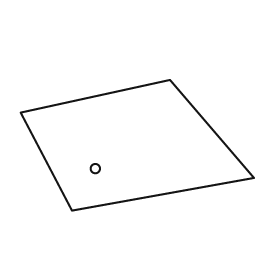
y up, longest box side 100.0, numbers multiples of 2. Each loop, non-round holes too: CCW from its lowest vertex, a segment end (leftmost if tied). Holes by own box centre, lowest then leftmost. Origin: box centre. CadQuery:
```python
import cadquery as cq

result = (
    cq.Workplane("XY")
    .moveTo(-28.0, -28.0)
    .lineTo(50.0, -14.0)
    .lineTo(14.0, 28.0)
    .lineTo(-50.0, 14.0)
    .close()
    .moveTo(-18.0, -10.0)
    .circle(2.0)
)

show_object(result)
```